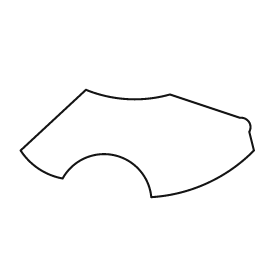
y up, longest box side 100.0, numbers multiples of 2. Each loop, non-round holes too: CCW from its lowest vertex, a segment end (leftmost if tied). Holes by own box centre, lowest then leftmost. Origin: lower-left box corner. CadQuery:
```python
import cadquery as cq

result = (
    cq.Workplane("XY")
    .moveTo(56.0, 0.0)
    .threePointArc((80.0, 6.0), (100.0, 20.0))
    .lineTo(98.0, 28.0)
    .threePointArc((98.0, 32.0), (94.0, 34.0))
    .lineTo(64.0, 44.0)
    .threePointArc((46.0, 42.0), (28.0, 46.0))
    .lineTo(0.0, 20.0)
    .threePointArc((8.0, 12.0), (18.0, 8.0))
    .threePointArc((40.0, 18.0), (56.0, 0.0))
    .close()
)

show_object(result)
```